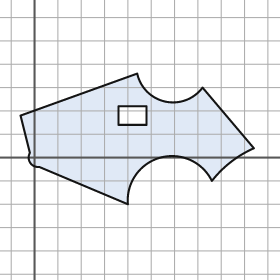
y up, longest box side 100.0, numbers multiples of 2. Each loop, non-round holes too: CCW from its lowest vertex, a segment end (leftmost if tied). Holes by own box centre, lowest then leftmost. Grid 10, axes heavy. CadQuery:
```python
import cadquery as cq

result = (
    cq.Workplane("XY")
    .moveTo(40.0, -20.0)
    .threePointArc((54.0, 0.0), (76.0, -10.0))
    .threePointArc((84.0, -2.0), (94.0, 4.0))
    .lineTo(72.0, 30.0)
    .threePointArc((56.0, 24.0), (44.0, 36.0))
    .lineTo(-6.0, 18.0)
    .lineTo(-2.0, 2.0)
    .threePointArc((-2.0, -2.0), (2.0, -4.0))
    .close()
    .moveTo(36.0, 14.0)
    .lineTo(48.0, 14.0)
    .lineTo(48.0, 22.0)
    .lineTo(36.0, 22.0)
    .close()
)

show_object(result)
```